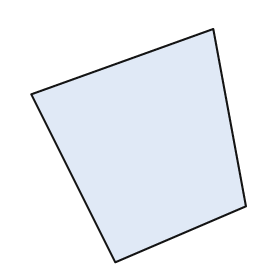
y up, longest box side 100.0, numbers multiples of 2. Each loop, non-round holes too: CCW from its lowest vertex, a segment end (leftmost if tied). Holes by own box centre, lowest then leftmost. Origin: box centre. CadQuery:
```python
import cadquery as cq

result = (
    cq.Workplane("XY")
    .moveTo(-10.0, -50.0)
    .lineTo(46.0, -26.0)
    .lineTo(32.0, 50.0)
    .lineTo(-46.0, 22.0)
    .close()
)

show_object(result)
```